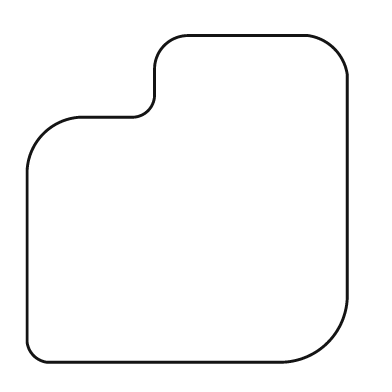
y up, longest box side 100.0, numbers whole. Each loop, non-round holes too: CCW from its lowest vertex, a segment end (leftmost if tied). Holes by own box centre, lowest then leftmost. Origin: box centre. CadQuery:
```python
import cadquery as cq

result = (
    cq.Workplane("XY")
    .moveTo(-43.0, -50.0)
    .lineTo(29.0, -50.0)
    .threePointArc((43.0, -44.0), (49.0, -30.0))
    .lineTo(49.0, 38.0)
    .threePointArc((45.0, 46.0), (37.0, 50.0))
    .lineTo(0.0, 50.0)
    .threePointArc((-7.0, 47.0), (-10.0, 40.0))
    .lineTo(-10.0, 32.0)
    .threePointArc((-12.0, 27.0), (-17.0, 25.0))
    .lineTo(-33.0, 25.0)
    .threePointArc((-44.0, 20.0), (-49.0, 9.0))
    .lineTo(-49.0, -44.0)
    .threePointArc((-47.0, -48.0), (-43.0, -50.0))
    .close()
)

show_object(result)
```